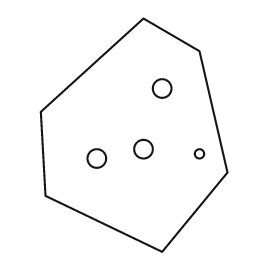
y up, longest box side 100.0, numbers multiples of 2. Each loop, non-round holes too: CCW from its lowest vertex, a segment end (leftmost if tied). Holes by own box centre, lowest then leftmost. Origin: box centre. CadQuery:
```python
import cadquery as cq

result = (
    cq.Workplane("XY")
    .moveTo(12.0, -50.0)
    .lineTo(40.0, -16.0)
    .lineTo(28.0, 36.0)
    .lineTo(4.0, 50.0)
    .lineTo(-40.0, 10.0)
    .lineTo(-38.0, -26.0)
    .close()
    .moveTo(-16.0, -10.0)
    .circle(4.0)
    .moveTo(28.0, -8.0)
    .circle(2.0)
    .moveTo(4.0, -6.0)
    .circle(4.0)
    .moveTo(12.0, 20.0)
    .circle(4.0)
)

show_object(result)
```